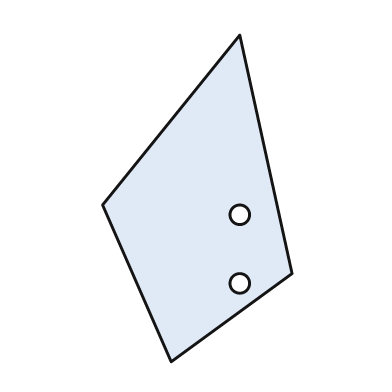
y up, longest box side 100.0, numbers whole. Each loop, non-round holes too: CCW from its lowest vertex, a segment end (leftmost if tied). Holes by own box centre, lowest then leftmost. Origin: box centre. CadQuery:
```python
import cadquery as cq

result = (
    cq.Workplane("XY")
    .moveTo(-8.0, -50.0)
    .lineTo(29.0, -23.0)
    .lineTo(13.0, 50.0)
    .lineTo(-29.0, -2.0)
    .close()
    .moveTo(13.0, -26.0)
    .circle(3.0)
    .moveTo(13.0, -5.0)
    .circle(3.0)
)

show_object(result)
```